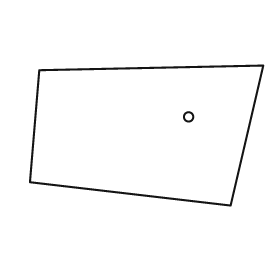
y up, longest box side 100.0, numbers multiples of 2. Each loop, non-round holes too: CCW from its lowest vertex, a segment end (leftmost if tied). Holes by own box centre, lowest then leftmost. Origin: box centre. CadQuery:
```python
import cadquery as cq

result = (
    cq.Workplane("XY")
    .moveTo(36.0, -30.0)
    .lineTo(50.0, 30.0)
    .lineTo(-46.0, 28.0)
    .lineTo(-50.0, -20.0)
    .close()
    .moveTo(18.0, 8.0)
    .circle(2.0)
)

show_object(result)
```